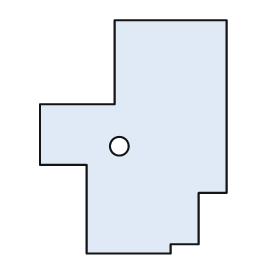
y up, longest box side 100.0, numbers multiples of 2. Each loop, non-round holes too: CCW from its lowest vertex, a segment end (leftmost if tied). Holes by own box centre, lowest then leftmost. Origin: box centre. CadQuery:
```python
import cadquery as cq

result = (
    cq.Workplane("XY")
    .moveTo(-20.0, -50.0)
    .lineTo(16.0, -50.0)
    .lineTo(16.0, -46.0)
    .lineTo(28.0, -46.0)
    .lineTo(28.0, -24.0)
    .lineTo(40.0, -24.0)
    .lineTo(40.0, 50.0)
    .lineTo(-8.0, 50.0)
    .lineTo(-8.0, 14.0)
    .lineTo(-40.0, 14.0)
    .lineTo(-40.0, -12.0)
    .lineTo(-20.0, -12.0)
    .close()
    .moveTo(-6.0, -4.0)
    .circle(4.0)
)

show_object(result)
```